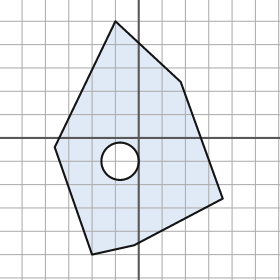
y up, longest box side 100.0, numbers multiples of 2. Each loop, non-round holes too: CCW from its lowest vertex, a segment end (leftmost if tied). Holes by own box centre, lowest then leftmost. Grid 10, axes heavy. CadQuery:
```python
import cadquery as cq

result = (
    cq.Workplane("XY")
    .moveTo(-20.0, -50.0)
    .lineTo(-2.0, -46.0)
    .lineTo(36.0, -26.0)
    .lineTo(18.0, 24.0)
    .lineTo(-10.0, 50.0)
    .lineTo(-36.0, -4.0)
    .close()
    .moveTo(-8.0, -10.0)
    .circle(8.0)
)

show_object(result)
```